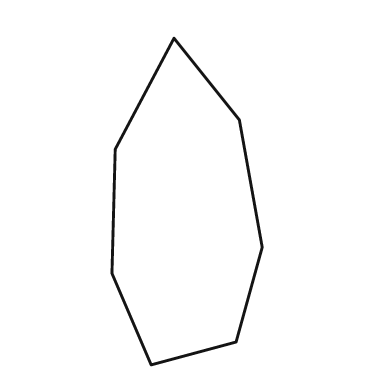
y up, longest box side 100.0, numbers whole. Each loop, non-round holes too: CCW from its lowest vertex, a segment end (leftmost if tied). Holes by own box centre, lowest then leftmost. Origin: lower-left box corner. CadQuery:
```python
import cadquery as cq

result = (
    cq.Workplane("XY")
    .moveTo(12.0, 0.0)
    .lineTo(38.0, 7.0)
    .lineTo(46.0, 36.0)
    .lineTo(39.0, 75.0)
    .lineTo(19.0, 100.0)
    .lineTo(1.0, 66.0)
    .lineTo(0.0, 28.0)
    .close()
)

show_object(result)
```